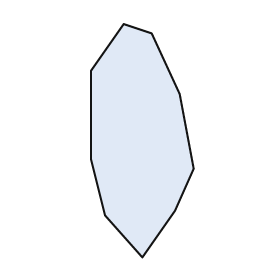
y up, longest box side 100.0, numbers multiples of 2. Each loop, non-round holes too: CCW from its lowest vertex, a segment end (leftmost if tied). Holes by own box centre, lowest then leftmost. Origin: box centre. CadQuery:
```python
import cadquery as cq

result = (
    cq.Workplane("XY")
    .moveTo(0.0, -50.0)
    .lineTo(14.0, -30.0)
    .lineTo(22.0, -12.0)
    .lineTo(16.0, 20.0)
    .lineTo(4.0, 46.0)
    .lineTo(-8.0, 50.0)
    .lineTo(-22.0, 30.0)
    .lineTo(-22.0, -8.0)
    .lineTo(-16.0, -32.0)
    .close()
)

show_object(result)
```